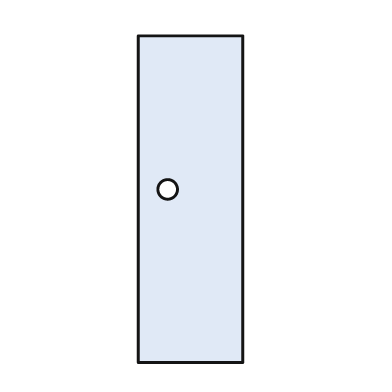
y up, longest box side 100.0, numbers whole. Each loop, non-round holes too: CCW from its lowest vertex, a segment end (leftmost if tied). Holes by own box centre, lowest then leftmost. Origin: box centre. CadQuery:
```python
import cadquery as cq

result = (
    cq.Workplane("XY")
    .moveTo(-16.0, -50.0)
    .lineTo(16.0, -50.0)
    .lineTo(16.0, 50.0)
    .lineTo(-16.0, 50.0)
    .close()
    .moveTo(-7.0, 3.0)
    .circle(3.0)
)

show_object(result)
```